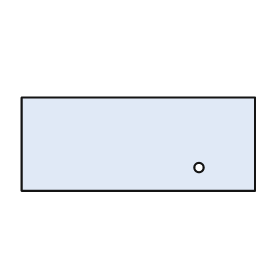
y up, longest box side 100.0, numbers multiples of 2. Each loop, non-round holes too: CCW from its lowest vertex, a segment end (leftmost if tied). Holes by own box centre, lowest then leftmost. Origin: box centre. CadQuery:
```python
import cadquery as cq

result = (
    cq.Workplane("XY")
    .moveTo(-50.0, -20.0)
    .lineTo(50.0, -20.0)
    .lineTo(50.0, 20.0)
    .lineTo(-50.0, 20.0)
    .close()
    .moveTo(26.0, -10.0)
    .circle(2.0)
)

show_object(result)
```